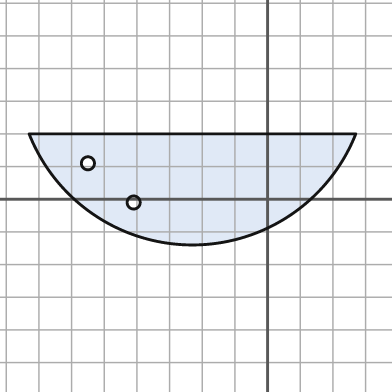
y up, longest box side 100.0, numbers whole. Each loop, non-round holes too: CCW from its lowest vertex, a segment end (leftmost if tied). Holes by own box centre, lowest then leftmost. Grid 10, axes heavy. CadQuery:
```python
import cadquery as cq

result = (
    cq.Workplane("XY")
    .moveTo(-73.0, 20.0)
    .threePointArc((-23.0, -14.0), (27.0, 20.0))
    .close()
    .moveTo(-41.0, -1.0)
    .circle(2.0)
    .moveTo(-55.0, 11.0)
    .circle(2.0)
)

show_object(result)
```